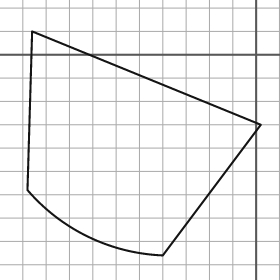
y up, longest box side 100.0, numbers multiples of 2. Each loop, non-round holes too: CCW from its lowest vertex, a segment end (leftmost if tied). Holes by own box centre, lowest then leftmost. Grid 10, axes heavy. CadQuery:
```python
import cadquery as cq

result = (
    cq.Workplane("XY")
    .moveTo(-40.0, -86.0)
    .lineTo(2.0, -30.0)
    .lineTo(-96.0, 10.0)
    .lineTo(-98.0, -58.0)
    .threePointArc((-72.0, -78.0), (-40.0, -86.0))
    .close()
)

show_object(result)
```